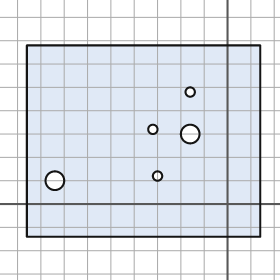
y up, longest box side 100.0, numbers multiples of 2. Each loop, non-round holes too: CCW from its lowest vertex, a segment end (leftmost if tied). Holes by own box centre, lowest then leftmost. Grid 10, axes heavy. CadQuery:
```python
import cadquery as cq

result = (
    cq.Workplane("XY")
    .moveTo(-86.0, -14.0)
    .lineTo(14.0, -14.0)
    .lineTo(14.0, 68.0)
    .lineTo(-86.0, 68.0)
    .close()
    .moveTo(-74.0, 10.0)
    .circle(4.0)
    .moveTo(-30.0, 12.0)
    .circle(2.0)
    .moveTo(-16.0, 30.0)
    .circle(4.0)
    .moveTo(-32.0, 32.0)
    .circle(2.0)
    .moveTo(-16.0, 48.0)
    .circle(2.0)
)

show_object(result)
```